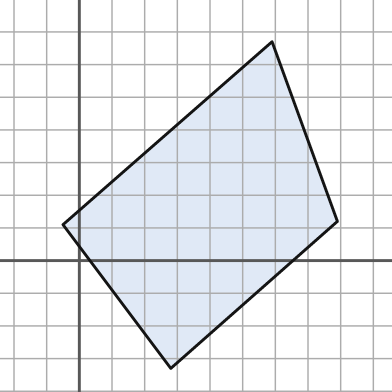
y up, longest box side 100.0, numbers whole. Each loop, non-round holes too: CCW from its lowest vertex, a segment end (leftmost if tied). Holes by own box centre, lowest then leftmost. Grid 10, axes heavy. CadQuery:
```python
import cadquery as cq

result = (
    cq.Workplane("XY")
    .moveTo(28.0, -33.0)
    .lineTo(79.0, 12.0)
    .lineTo(59.0, 67.0)
    .lineTo(-5.0, 11.0)
    .close()
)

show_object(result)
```